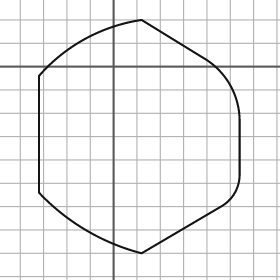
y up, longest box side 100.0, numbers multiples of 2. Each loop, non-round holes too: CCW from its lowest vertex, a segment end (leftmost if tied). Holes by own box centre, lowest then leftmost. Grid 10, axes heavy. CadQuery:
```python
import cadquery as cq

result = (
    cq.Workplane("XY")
    .moveTo(12.0, -80.0)
    .lineTo(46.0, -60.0)
    .threePointArc((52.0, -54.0), (54.0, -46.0))
    .lineTo(54.0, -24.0)
    .threePointArc((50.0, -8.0), (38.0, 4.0))
    .lineTo(12.0, 20.0)
    .threePointArc((-12.0, 12.0), (-32.0, -4.0))
    .lineTo(-32.0, -54.0)
    .threePointArc((-12.0, -70.0), (12.0, -80.0))
    .close()
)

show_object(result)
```